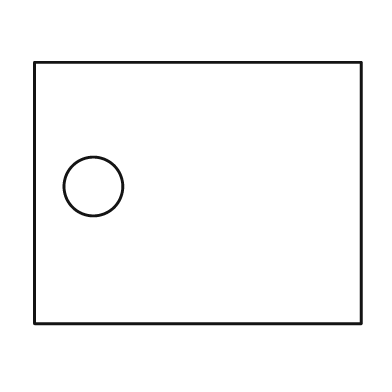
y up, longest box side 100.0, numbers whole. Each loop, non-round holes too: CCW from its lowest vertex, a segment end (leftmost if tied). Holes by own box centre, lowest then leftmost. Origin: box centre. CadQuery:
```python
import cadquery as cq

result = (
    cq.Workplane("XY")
    .moveTo(-50.0, -40.0)
    .lineTo(50.0, -40.0)
    .lineTo(50.0, 40.0)
    .lineTo(-50.0, 40.0)
    .close()
    .moveTo(-32.0, 2.0)
    .circle(9.0)
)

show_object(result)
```